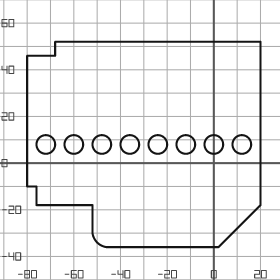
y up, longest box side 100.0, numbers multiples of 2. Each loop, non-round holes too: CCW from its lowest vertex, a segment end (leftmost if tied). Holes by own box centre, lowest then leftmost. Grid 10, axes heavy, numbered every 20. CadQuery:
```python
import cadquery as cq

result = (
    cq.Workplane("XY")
    .moveTo(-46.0, -36.0)
    .lineTo(2.0, -36.0)
    .lineTo(20.0, -18.0)
    .lineTo(20.0, 52.0)
    .lineTo(-68.0, 52.0)
    .lineTo(-68.0, 46.0)
    .lineTo(-80.0, 46.0)
    .lineTo(-80.0, -10.0)
    .lineTo(-76.0, -10.0)
    .lineTo(-76.0, -18.0)
    .lineTo(-52.0, -18.0)
    .lineTo(-52.0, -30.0)
    .threePointArc((-50.0, -34.0), (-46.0, -36.0))
    .close()
    .moveTo(-72.0, 8.0)
    .circle(4.0)
    .moveTo(-60.0, 8.0)
    .circle(4.0)
    .moveTo(-48.0, 8.0)
    .circle(4.0)
    .moveTo(-36.0, 8.0)
    .circle(4.0)
    .moveTo(-24.0, 8.0)
    .circle(4.0)
    .moveTo(-12.0, 8.0)
    .circle(4.0)
    .moveTo(0.0, 8.0)
    .circle(4.0)
    .moveTo(12.0, 8.0)
    .circle(4.0)
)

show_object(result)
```